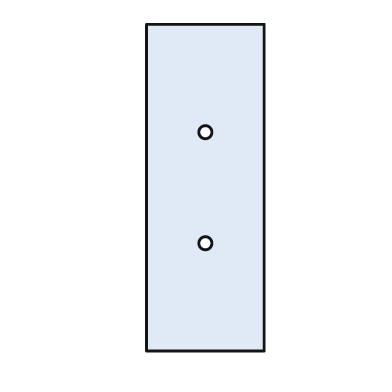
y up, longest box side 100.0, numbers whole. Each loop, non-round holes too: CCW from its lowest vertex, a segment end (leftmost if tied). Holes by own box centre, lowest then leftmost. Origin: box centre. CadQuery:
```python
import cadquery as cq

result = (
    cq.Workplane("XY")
    .moveTo(-18.0, -50.0)
    .lineTo(18.0, -50.0)
    .lineTo(18.0, 50.0)
    .lineTo(-18.0, 50.0)
    .close()
    .moveTo(0.0, -17.0)
    .circle(2.0)
    .moveTo(0.0, 17.0)
    .circle(2.0)
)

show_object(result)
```